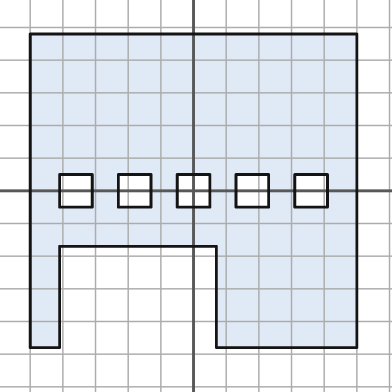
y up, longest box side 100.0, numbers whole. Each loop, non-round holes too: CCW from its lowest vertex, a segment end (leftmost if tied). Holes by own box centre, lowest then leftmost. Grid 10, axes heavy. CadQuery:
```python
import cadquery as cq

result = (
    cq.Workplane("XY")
    .moveTo(-50.0, -48.0)
    .lineTo(-41.0, -48.0)
    .lineTo(-41.0, -17.0)
    .lineTo(7.0, -17.0)
    .lineTo(7.0, -48.0)
    .lineTo(50.0, -48.0)
    .lineTo(50.0, 48.0)
    .lineTo(-50.0, 48.0)
    .close()
    .moveTo(-41.0, -5.0)
    .lineTo(-31.0, -5.0)
    .lineTo(-31.0, 5.0)
    .lineTo(-41.0, 5.0)
    .close()
    .moveTo(-23.0, -5.0)
    .lineTo(-13.0, -5.0)
    .lineTo(-13.0, 5.0)
    .lineTo(-23.0, 5.0)
    .close()
    .moveTo(-5.0, -5.0)
    .lineTo(5.0, -5.0)
    .lineTo(5.0, 5.0)
    .lineTo(-5.0, 5.0)
    .close()
    .moveTo(13.0, -5.0)
    .lineTo(23.0, -5.0)
    .lineTo(23.0, 5.0)
    .lineTo(13.0, 5.0)
    .close()
    .moveTo(31.0, -5.0)
    .lineTo(41.0, -5.0)
    .lineTo(41.0, 5.0)
    .lineTo(31.0, 5.0)
    .close()
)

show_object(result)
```